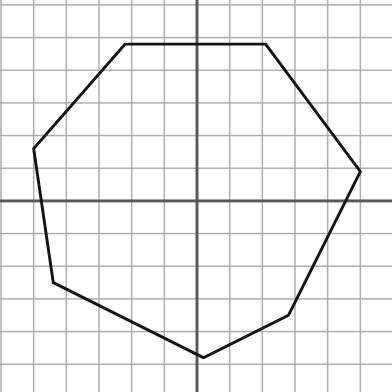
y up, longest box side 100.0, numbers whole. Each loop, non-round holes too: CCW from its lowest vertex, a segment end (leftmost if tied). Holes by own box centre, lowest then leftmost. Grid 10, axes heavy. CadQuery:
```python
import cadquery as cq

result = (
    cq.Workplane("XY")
    .moveTo(2.0, -48.0)
    .lineTo(28.0, -35.0)
    .lineTo(50.0, 9.0)
    .lineTo(21.0, 48.0)
    .lineTo(-22.0, 48.0)
    .lineTo(-50.0, 16.0)
    .lineTo(-44.0, -25.0)
    .close()
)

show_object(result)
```